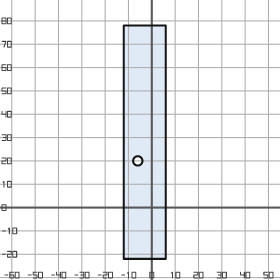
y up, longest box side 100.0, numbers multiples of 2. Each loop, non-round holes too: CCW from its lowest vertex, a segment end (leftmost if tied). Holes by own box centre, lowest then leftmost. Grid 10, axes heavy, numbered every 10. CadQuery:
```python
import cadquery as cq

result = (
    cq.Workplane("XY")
    .moveTo(-12.0, -22.0)
    .lineTo(6.0, -22.0)
    .lineTo(6.0, 78.0)
    .lineTo(-12.0, 78.0)
    .close()
    .moveTo(-6.0, 20.0)
    .circle(2.0)
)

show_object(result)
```